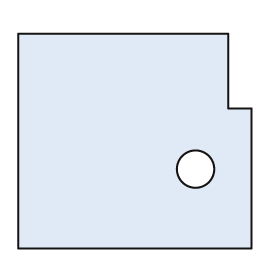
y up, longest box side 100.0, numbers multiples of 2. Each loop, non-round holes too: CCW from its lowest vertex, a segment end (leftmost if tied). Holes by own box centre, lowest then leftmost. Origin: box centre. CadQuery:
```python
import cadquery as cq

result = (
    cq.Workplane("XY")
    .moveTo(-50.0, -46.0)
    .lineTo(50.0, -46.0)
    .lineTo(50.0, 14.0)
    .lineTo(40.0, 14.0)
    .lineTo(40.0, 46.0)
    .lineTo(-50.0, 46.0)
    .close()
    .moveTo(26.0, -12.0)
    .circle(8.0)
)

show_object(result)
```